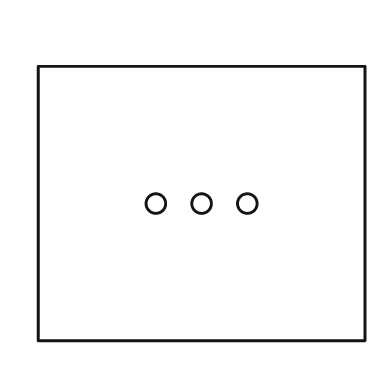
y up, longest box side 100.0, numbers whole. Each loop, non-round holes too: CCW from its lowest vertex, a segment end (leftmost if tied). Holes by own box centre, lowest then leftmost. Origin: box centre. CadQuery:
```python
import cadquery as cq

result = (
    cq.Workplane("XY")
    .moveTo(-50.0, -42.0)
    .lineTo(50.0, -42.0)
    .lineTo(50.0, 42.0)
    .lineTo(-50.0, 42.0)
    .close()
    .moveTo(-14.0, 0.0)
    .circle(3.0)
    .moveTo(0.0, 0.0)
    .circle(3.0)
    .moveTo(14.0, 0.0)
    .circle(3.0)
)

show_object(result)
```